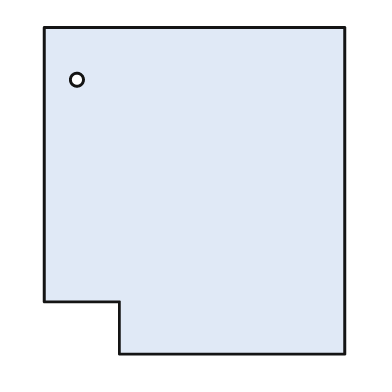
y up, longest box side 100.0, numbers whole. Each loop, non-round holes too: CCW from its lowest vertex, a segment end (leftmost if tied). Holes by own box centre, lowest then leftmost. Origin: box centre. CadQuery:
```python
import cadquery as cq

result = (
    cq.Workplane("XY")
    .moveTo(-23.0, -50.0)
    .lineTo(46.0, -50.0)
    .lineTo(46.0, 50.0)
    .lineTo(-46.0, 50.0)
    .lineTo(-46.0, -34.0)
    .lineTo(-23.0, -34.0)
    .close()
    .moveTo(-36.0, 34.0)
    .circle(2.0)
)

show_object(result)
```